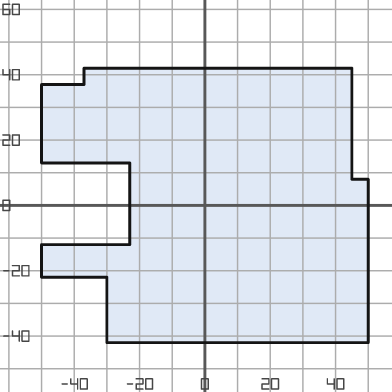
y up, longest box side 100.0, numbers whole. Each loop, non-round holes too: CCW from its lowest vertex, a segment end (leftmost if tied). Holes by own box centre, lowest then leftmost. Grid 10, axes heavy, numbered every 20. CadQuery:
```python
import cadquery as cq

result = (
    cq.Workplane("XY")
    .moveTo(-30.0, -42.0)
    .lineTo(50.0, -42.0)
    .lineTo(50.0, 8.0)
    .lineTo(45.0, 8.0)
    .lineTo(45.0, 42.0)
    .lineTo(-37.0, 42.0)
    .lineTo(-37.0, 37.0)
    .lineTo(-50.0, 37.0)
    .lineTo(-50.0, 13.0)
    .lineTo(-23.0, 13.0)
    .lineTo(-23.0, -12.0)
    .lineTo(-50.0, -12.0)
    .lineTo(-50.0, -22.0)
    .lineTo(-30.0, -22.0)
    .close()
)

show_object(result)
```